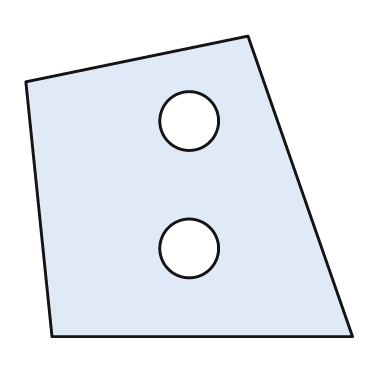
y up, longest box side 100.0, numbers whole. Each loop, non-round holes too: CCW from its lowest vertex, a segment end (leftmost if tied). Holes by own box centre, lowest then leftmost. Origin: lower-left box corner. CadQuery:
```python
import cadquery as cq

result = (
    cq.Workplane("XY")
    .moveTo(8.0, 0.0)
    .lineTo(100.0, 0.0)
    .lineTo(68.0, 92.0)
    .lineTo(0.0, 78.0)
    .close()
    .moveTo(50.0, 27.0)
    .circle(9.0)
    .moveTo(50.0, 66.0)
    .circle(9.0)
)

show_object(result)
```